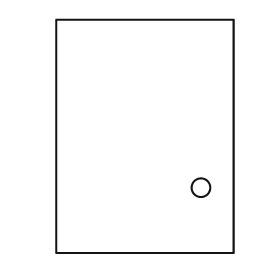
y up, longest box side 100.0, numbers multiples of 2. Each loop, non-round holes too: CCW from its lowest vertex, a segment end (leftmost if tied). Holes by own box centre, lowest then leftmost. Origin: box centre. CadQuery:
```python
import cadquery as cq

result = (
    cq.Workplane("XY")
    .moveTo(-38.0, -50.0)
    .lineTo(38.0, -50.0)
    .lineTo(38.0, 50.0)
    .lineTo(-38.0, 50.0)
    .close()
    .moveTo(24.0, -22.0)
    .circle(4.0)
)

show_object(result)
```